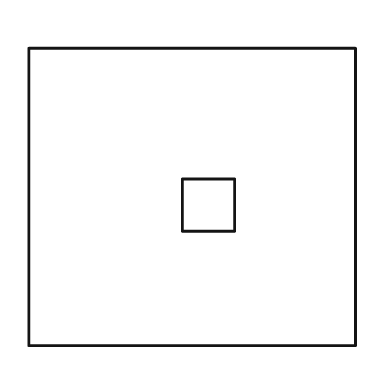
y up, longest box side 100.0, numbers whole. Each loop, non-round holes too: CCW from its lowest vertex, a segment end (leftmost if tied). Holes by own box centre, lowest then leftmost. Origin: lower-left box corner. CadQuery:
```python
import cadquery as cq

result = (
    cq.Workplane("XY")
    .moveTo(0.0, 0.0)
    .lineTo(100.0, 0.0)
    .lineTo(100.0, 91.0)
    .lineTo(0.0, 91.0)
    .close()
    .moveTo(47.0, 35.0)
    .lineTo(63.0, 35.0)
    .lineTo(63.0, 51.0)
    .lineTo(47.0, 51.0)
    .close()
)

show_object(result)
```